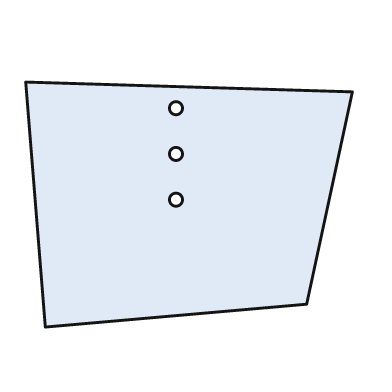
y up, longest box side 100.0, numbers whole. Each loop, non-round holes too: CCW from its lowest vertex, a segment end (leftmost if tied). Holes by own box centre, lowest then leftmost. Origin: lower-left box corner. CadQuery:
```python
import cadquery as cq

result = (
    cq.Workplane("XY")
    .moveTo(6.0, 0.0)
    .lineTo(86.0, 7.0)
    .lineTo(100.0, 72.0)
    .lineTo(0.0, 75.0)
    .close()
    .moveTo(46.0, 39.0)
    .circle(2.0)
    .moveTo(46.0, 53.0)
    .circle(2.0)
    .moveTo(46.0, 67.0)
    .circle(2.0)
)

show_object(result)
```